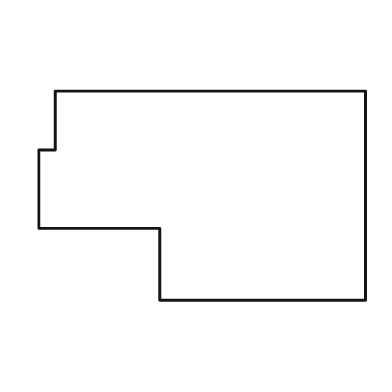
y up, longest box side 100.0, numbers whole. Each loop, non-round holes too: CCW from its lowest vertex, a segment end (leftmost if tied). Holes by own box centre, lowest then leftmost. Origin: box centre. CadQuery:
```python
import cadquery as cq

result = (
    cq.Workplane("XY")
    .moveTo(-13.0, -32.0)
    .lineTo(50.0, -32.0)
    .lineTo(50.0, 32.0)
    .lineTo(-45.0, 32.0)
    .lineTo(-45.0, 14.0)
    .lineTo(-50.0, 14.0)
    .lineTo(-50.0, -10.0)
    .lineTo(-13.0, -10.0)
    .close()
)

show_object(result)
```